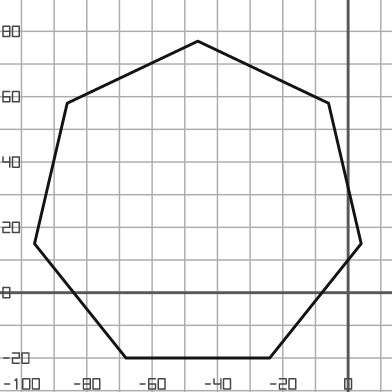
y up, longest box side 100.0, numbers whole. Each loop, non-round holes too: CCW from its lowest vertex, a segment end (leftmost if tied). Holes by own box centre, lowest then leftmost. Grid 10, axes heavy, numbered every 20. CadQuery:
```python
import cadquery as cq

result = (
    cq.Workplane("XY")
    .moveTo(-68.0, -20.0)
    .lineTo(-24.0, -20.0)
    .lineTo(4.0, 15.0)
    .lineTo(-6.0, 58.0)
    .lineTo(-46.0, 77.0)
    .lineTo(-86.0, 58.0)
    .lineTo(-96.0, 15.0)
    .close()
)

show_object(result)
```